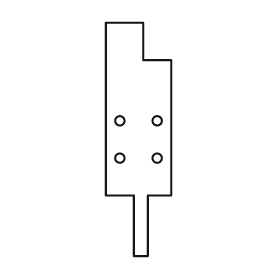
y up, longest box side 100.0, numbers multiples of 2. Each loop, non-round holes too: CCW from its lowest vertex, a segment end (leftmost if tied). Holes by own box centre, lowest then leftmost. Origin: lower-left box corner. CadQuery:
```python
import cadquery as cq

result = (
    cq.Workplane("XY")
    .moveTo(12.0, 0.0)
    .lineTo(18.0, 0.0)
    .lineTo(18.0, 26.0)
    .lineTo(28.0, 26.0)
    .lineTo(28.0, 84.0)
    .lineTo(16.0, 84.0)
    .lineTo(16.0, 100.0)
    .lineTo(0.0, 100.0)
    .lineTo(0.0, 26.0)
    .lineTo(12.0, 26.0)
    .close()
    .moveTo(6.0, 42.0)
    .circle(2.0)
    .moveTo(22.0, 42.0)
    .circle(2.0)
    .moveTo(6.0, 58.0)
    .circle(2.0)
    .moveTo(22.0, 58.0)
    .circle(2.0)
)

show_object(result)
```